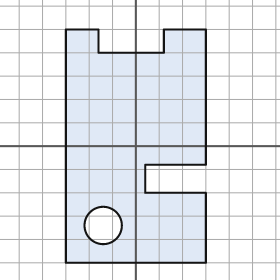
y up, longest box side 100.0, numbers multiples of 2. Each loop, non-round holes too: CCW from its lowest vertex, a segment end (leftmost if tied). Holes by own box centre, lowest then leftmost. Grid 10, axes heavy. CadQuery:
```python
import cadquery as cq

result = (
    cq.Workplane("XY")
    .moveTo(-30.0, -50.0)
    .lineTo(30.0, -50.0)
    .lineTo(30.0, -20.0)
    .lineTo(4.0, -20.0)
    .lineTo(4.0, -8.0)
    .lineTo(30.0, -8.0)
    .lineTo(30.0, 50.0)
    .lineTo(12.0, 50.0)
    .lineTo(12.0, 40.0)
    .lineTo(-16.0, 40.0)
    .lineTo(-16.0, 50.0)
    .lineTo(-30.0, 50.0)
    .close()
    .moveTo(-14.0, -34.0)
    .circle(8.0)
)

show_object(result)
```